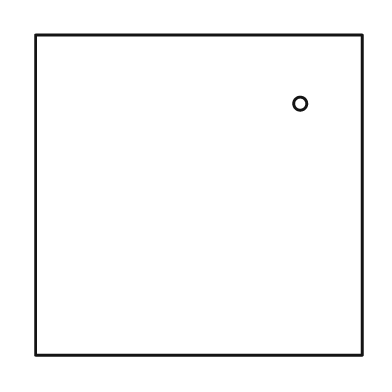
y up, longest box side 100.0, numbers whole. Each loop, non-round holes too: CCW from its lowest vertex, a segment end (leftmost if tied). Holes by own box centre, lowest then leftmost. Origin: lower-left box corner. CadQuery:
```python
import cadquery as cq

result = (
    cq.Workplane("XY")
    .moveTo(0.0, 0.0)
    .lineTo(100.0, 0.0)
    .lineTo(100.0, 98.0)
    .lineTo(0.0, 98.0)
    .close()
    .moveTo(81.0, 77.0)
    .circle(2.0)
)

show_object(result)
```